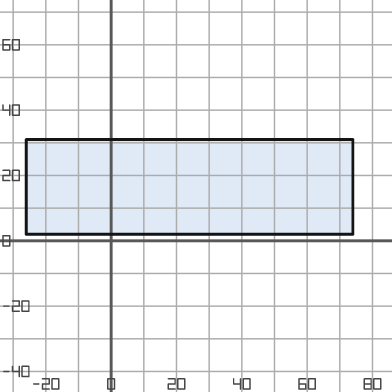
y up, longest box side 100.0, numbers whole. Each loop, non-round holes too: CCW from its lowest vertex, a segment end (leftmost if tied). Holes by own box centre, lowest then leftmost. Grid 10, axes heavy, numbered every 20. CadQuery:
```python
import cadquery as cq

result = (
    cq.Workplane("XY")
    .moveTo(-26.0, 2.0)
    .lineTo(74.0, 2.0)
    .lineTo(74.0, 31.0)
    .lineTo(-26.0, 31.0)
    .close()
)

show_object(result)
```